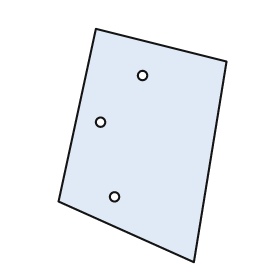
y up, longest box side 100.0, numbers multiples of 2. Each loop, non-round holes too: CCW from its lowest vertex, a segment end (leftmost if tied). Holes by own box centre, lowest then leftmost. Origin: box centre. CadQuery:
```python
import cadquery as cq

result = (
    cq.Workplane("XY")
    .moveTo(22.0, -50.0)
    .lineTo(36.0, 36.0)
    .lineTo(-20.0, 50.0)
    .lineTo(-36.0, -24.0)
    .close()
    .moveTo(-12.0, -22.0)
    .circle(2.0)
    .moveTo(-18.0, 10.0)
    .circle(2.0)
    .moveTo(0.0, 30.0)
    .circle(2.0)
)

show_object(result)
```